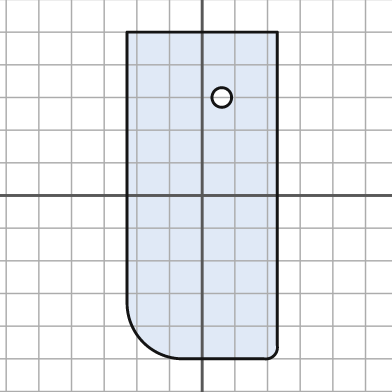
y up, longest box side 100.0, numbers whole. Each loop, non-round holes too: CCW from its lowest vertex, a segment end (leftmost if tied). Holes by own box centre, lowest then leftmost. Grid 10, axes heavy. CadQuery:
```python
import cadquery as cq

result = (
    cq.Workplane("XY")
    .moveTo(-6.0, -50.0)
    .lineTo(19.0, -50.0)
    .threePointArc((22.0, -49.0), (23.0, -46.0))
    .lineTo(23.0, 50.0)
    .lineTo(-23.0, 50.0)
    .lineTo(-23.0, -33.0)
    .threePointArc((-18.0, -45.0), (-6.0, -50.0))
    .close()
    .moveTo(6.0, 30.0)
    .circle(3.0)
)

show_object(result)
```